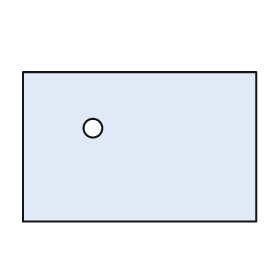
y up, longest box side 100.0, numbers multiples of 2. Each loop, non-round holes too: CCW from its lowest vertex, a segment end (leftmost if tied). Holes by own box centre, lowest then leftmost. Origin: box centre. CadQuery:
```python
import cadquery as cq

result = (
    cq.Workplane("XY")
    .moveTo(-50.0, -32.0)
    .lineTo(50.0, -32.0)
    .lineTo(50.0, 32.0)
    .lineTo(-50.0, 32.0)
    .close()
    .moveTo(-20.0, 8.0)
    .circle(4.0)
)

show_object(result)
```